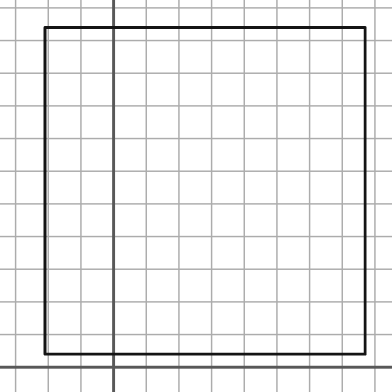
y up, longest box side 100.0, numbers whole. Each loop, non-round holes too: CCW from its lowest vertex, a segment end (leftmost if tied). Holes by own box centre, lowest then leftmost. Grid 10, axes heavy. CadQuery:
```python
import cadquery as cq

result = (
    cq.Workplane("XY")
    .moveTo(-21.0, 4.0)
    .lineTo(77.0, 4.0)
    .lineTo(77.0, 104.0)
    .lineTo(-21.0, 104.0)
    .close()
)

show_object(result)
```